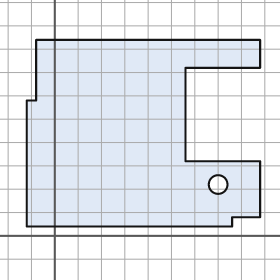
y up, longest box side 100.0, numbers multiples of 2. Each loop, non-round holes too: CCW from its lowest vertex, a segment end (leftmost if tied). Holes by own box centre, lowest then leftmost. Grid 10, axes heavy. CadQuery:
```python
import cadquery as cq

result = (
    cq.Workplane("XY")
    .moveTo(-12.0, 4.0)
    .lineTo(76.0, 4.0)
    .lineTo(76.0, 8.0)
    .lineTo(88.0, 8.0)
    .lineTo(88.0, 32.0)
    .lineTo(56.0, 32.0)
    .lineTo(56.0, 72.0)
    .lineTo(88.0, 72.0)
    .lineTo(88.0, 84.0)
    .lineTo(-8.0, 84.0)
    .lineTo(-8.0, 58.0)
    .lineTo(-12.0, 58.0)
    .close()
    .moveTo(70.0, 22.0)
    .circle(4.0)
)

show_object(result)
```